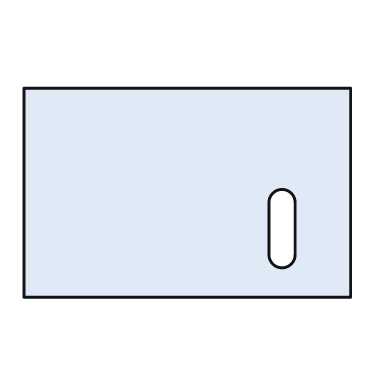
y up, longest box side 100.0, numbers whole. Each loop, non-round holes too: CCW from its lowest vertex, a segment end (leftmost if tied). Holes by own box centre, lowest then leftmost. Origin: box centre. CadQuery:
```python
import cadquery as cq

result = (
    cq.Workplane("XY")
    .moveTo(-50.0, -32.0)
    .lineTo(50.0, -32.0)
    .lineTo(50.0, 32.0)
    .lineTo(-50.0, 32.0)
    .close()
    .moveTo(25.0, -19.0)
    .threePointArc((29.0, -23.0), (33.0, -19.0))
    .lineTo(33.0, -3.0)
    .threePointArc((29.0, 1.0), (25.0, -3.0))
    .close()
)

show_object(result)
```